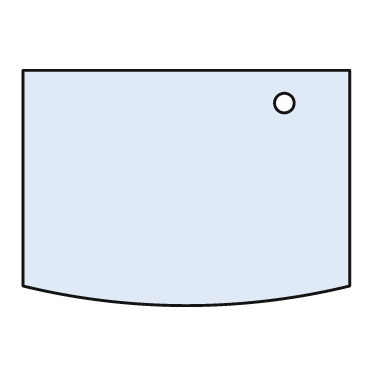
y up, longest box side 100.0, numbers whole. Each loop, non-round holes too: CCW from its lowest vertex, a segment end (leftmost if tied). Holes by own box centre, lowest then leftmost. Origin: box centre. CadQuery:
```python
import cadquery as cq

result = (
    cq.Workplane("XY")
    .moveTo(-50.0, -30.0)
    .threePointArc((0.0, -36.0), (50.0, -30.0))
    .lineTo(50.0, 36.0)
    .lineTo(-50.0, 36.0)
    .close()
    .moveTo(30.0, 26.0)
    .circle(3.0)
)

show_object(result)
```